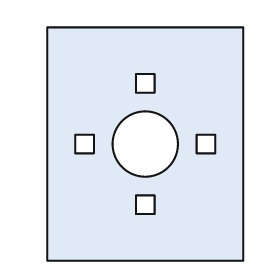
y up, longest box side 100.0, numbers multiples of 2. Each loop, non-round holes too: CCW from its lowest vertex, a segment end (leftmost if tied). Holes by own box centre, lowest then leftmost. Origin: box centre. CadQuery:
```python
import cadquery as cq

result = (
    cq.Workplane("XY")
    .moveTo(-42.0, -50.0)
    .lineTo(42.0, -50.0)
    .lineTo(42.0, 50.0)
    .lineTo(-42.0, 50.0)
    .close()
    .moveTo(-4.0, -30.0)
    .lineTo(4.0, -30.0)
    .lineTo(4.0, -22.0)
    .lineTo(-4.0, -22.0)
    .close()
    .moveTo(-30.0, -4.0)
    .lineTo(-22.0, -4.0)
    .lineTo(-22.0, 4.0)
    .lineTo(-30.0, 4.0)
    .close()
    .moveTo(0.0, 0.0)
    .circle(14.0)
    .moveTo(22.0, -4.0)
    .lineTo(30.0, -4.0)
    .lineTo(30.0, 4.0)
    .lineTo(22.0, 4.0)
    .close()
    .moveTo(-4.0, 22.0)
    .lineTo(4.0, 22.0)
    .lineTo(4.0, 30.0)
    .lineTo(-4.0, 30.0)
    .close()
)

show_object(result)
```